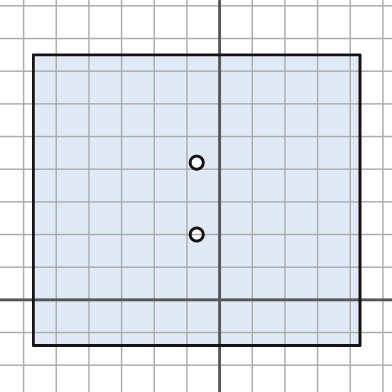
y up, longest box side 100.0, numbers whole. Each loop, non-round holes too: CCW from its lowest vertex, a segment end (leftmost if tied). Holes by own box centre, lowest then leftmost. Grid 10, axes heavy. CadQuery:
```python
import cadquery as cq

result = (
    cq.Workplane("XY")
    .moveTo(-57.0, -14.0)
    .lineTo(43.0, -14.0)
    .lineTo(43.0, 75.0)
    .lineTo(-57.0, 75.0)
    .close()
    .moveTo(-7.0, 20.0)
    .circle(2.0)
    .moveTo(-7.0, 42.0)
    .circle(2.0)
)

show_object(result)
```